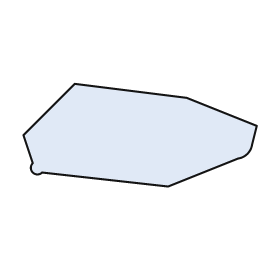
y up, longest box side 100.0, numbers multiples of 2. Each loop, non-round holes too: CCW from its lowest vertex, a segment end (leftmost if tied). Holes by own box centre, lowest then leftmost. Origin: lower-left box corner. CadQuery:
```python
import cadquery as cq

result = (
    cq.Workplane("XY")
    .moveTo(62.0, 0.0)
    .lineTo(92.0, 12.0)
    .threePointArc((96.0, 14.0), (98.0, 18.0))
    .lineTo(100.0, 26.0)
    .lineTo(70.0, 38.0)
    .lineTo(22.0, 44.0)
    .lineTo(0.0, 22.0)
    .lineTo(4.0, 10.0)
    .threePointArc((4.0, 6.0), (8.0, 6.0))
    .close()
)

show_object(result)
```